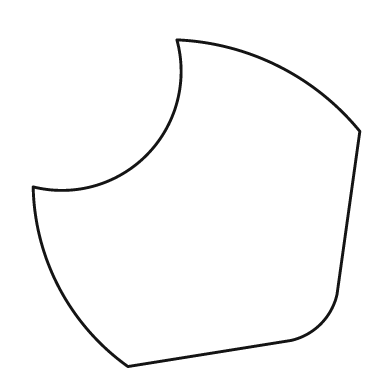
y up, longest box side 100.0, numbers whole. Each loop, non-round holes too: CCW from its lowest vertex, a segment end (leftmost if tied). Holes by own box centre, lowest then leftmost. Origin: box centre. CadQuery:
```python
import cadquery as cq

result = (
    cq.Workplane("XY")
    .moveTo(-21.0, -50.0)
    .lineTo(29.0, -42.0)
    .threePointArc((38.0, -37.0), (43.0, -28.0))
    .lineTo(50.0, 22.0)
    .threePointArc((25.0, 42.0), (-6.0, 50.0))
    .threePointArc((-15.0, 15.0), (-50.0, 5.0))
    .threePointArc((-42.0, -26.0), (-21.0, -50.0))
    .close()
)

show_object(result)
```